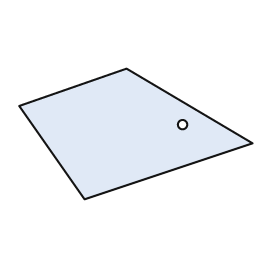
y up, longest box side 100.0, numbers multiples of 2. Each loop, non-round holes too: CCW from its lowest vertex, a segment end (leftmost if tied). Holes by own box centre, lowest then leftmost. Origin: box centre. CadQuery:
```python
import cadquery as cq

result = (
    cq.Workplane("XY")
    .moveTo(-22.0, -28.0)
    .lineTo(50.0, -4.0)
    .lineTo(-4.0, 28.0)
    .lineTo(-50.0, 12.0)
    .close()
    .moveTo(20.0, 4.0)
    .circle(2.0)
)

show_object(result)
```